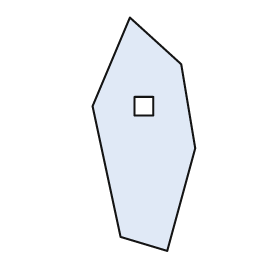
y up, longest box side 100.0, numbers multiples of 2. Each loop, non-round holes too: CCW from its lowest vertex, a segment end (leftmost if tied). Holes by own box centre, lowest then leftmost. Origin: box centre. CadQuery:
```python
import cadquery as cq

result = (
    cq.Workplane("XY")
    .moveTo(10.0, -50.0)
    .lineTo(22.0, -6.0)
    .lineTo(16.0, 30.0)
    .lineTo(-6.0, 50.0)
    .lineTo(-22.0, 12.0)
    .lineTo(-10.0, -44.0)
    .close()
    .moveTo(-4.0, 8.0)
    .lineTo(4.0, 8.0)
    .lineTo(4.0, 16.0)
    .lineTo(-4.0, 16.0)
    .close()
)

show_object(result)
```